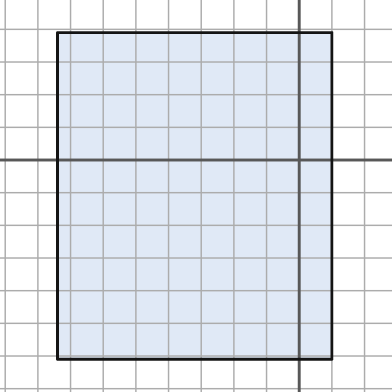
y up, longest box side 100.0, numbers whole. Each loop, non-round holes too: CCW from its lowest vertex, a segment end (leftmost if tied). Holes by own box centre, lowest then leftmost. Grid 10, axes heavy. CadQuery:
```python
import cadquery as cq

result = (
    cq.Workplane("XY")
    .moveTo(-74.0, -61.0)
    .lineTo(10.0, -61.0)
    .lineTo(10.0, 39.0)
    .lineTo(-74.0, 39.0)
    .close()
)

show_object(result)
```